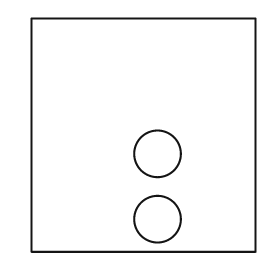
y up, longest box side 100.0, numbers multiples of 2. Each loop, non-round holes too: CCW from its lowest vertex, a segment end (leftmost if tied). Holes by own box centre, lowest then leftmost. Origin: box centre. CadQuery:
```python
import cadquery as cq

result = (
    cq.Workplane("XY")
    .moveTo(-48.0, -50.0)
    .lineTo(48.0, -50.0)
    .lineTo(48.0, 50.0)
    .lineTo(-48.0, 50.0)
    .close()
    .moveTo(6.0, -36.0)
    .circle(10.0)
    .moveTo(6.0, -8.0)
    .circle(10.0)
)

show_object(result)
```